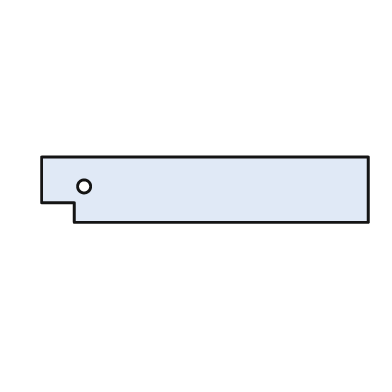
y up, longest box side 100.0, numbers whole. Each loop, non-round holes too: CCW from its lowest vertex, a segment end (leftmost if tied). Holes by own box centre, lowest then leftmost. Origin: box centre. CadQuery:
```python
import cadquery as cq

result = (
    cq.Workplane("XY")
    .moveTo(-40.0, -10.0)
    .lineTo(50.0, -10.0)
    .lineTo(50.0, 10.0)
    .lineTo(-50.0, 10.0)
    .lineTo(-50.0, -4.0)
    .lineTo(-40.0, -4.0)
    .close()
    .moveTo(-37.0, 1.0)
    .circle(2.0)
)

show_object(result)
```